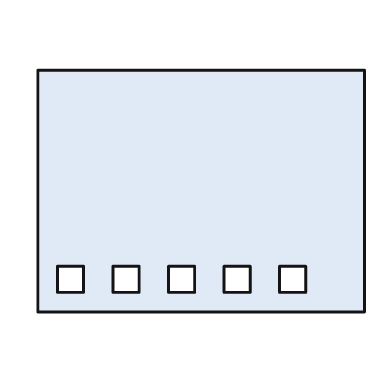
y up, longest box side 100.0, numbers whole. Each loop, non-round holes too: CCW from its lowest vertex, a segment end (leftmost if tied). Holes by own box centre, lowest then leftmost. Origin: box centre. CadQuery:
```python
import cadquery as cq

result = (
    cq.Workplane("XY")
    .moveTo(-50.0, -37.0)
    .lineTo(50.0, -37.0)
    .lineTo(50.0, 37.0)
    .lineTo(-50.0, 37.0)
    .close()
    .moveTo(-44.0, -31.0)
    .lineTo(-36.0, -31.0)
    .lineTo(-36.0, -23.0)
    .lineTo(-44.0, -23.0)
    .close()
    .moveTo(-27.0, -31.0)
    .lineTo(-19.0, -31.0)
    .lineTo(-19.0, -23.0)
    .lineTo(-27.0, -23.0)
    .close()
    .moveTo(-10.0, -31.0)
    .lineTo(-2.0, -31.0)
    .lineTo(-2.0, -23.0)
    .lineTo(-10.0, -23.0)
    .close()
    .moveTo(7.0, -31.0)
    .lineTo(15.0, -31.0)
    .lineTo(15.0, -23.0)
    .lineTo(7.0, -23.0)
    .close()
    .moveTo(24.0, -31.0)
    .lineTo(32.0, -31.0)
    .lineTo(32.0, -23.0)
    .lineTo(24.0, -23.0)
    .close()
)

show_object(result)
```